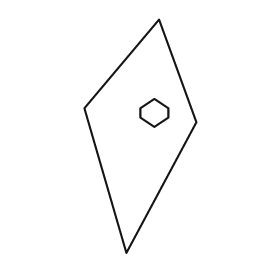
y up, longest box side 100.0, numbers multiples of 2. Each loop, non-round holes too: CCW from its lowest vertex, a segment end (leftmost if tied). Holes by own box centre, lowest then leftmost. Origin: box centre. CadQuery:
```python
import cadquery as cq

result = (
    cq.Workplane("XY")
    .moveTo(-6.0, -50.0)
    .lineTo(24.0, 6.0)
    .lineTo(8.0, 50.0)
    .lineTo(-24.0, 12.0)
    .close()
    .moveTo(6.0, 4.0)
    .lineTo(12.0, 8.0)
    .lineTo(12.0, 12.0)
    .lineTo(6.0, 16.0)
    .lineTo(0.0, 12.0)
    .lineTo(0.0, 8.0)
    .close()
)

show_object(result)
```